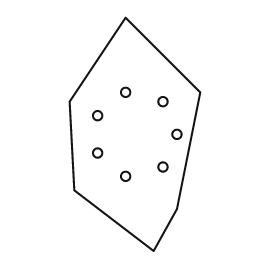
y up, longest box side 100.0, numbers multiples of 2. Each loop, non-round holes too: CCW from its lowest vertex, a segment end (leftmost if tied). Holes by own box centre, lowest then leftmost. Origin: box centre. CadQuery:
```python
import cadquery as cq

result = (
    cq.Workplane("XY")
    .moveTo(8.0, -50.0)
    .lineTo(18.0, -32.0)
    .lineTo(28.0, 18.0)
    .lineTo(-4.0, 50.0)
    .lineTo(-28.0, 14.0)
    .lineTo(-26.0, -24.0)
    .close()
    .moveTo(-4.0, -18.0)
    .circle(2.0)
    .moveTo(12.0, -14.0)
    .circle(2.0)
    .moveTo(-16.0, -8.0)
    .circle(2.0)
    .moveTo(18.0, 0.0)
    .circle(2.0)
    .moveTo(-16.0, 8.0)
    .circle(2.0)
    .moveTo(12.0, 14.0)
    .circle(2.0)
    .moveTo(-4.0, 18.0)
    .circle(2.0)
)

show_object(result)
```